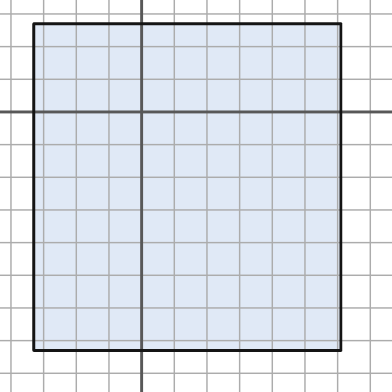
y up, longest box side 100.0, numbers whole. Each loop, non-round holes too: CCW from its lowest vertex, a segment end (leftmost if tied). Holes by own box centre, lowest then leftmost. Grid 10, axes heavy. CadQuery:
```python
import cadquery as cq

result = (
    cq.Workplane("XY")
    .moveTo(-33.0, -73.0)
    .lineTo(61.0, -73.0)
    .lineTo(61.0, 27.0)
    .lineTo(-33.0, 27.0)
    .close()
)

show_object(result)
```